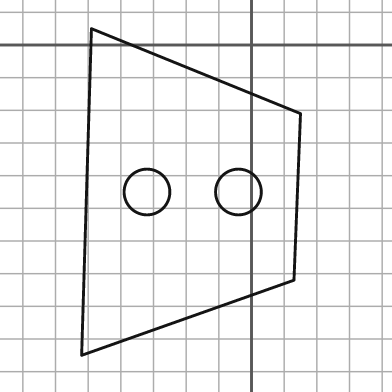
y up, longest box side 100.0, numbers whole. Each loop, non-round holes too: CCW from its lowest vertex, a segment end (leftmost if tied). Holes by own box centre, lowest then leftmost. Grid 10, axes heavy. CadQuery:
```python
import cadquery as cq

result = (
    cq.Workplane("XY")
    .moveTo(-52.0, -95.0)
    .lineTo(13.0, -72.0)
    .lineTo(15.0, -21.0)
    .lineTo(-49.0, 5.0)
    .close()
    .moveTo(-32.0, -45.0)
    .circle(7.0)
    .moveTo(-4.0, -45.0)
    .circle(7.0)
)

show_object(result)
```